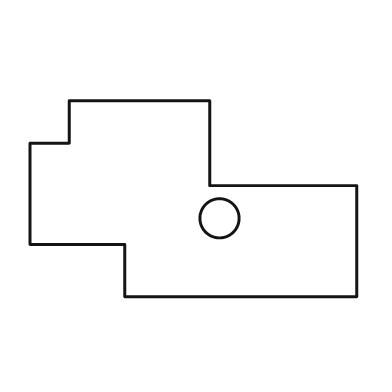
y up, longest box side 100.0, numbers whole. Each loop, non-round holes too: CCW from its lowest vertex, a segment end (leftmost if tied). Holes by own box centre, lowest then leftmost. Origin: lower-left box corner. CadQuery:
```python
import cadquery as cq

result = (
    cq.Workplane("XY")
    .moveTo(29.0, 0.0)
    .lineTo(100.0, 0.0)
    .lineTo(100.0, 34.0)
    .lineTo(55.0, 34.0)
    .lineTo(55.0, 60.0)
    .lineTo(12.0, 60.0)
    .lineTo(12.0, 47.0)
    .lineTo(0.0, 47.0)
    .lineTo(0.0, 16.0)
    .lineTo(29.0, 16.0)
    .close()
    .moveTo(58.0, 24.0)
    .circle(6.0)
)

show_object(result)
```